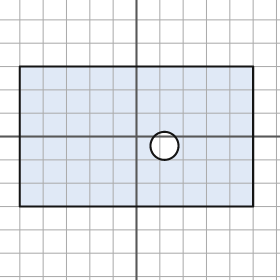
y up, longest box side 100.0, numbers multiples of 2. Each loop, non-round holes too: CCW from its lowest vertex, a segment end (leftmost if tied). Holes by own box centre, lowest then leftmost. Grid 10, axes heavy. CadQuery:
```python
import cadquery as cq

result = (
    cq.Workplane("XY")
    .moveTo(-50.0, -30.0)
    .lineTo(50.0, -30.0)
    .lineTo(50.0, 30.0)
    .lineTo(-50.0, 30.0)
    .close()
    .moveTo(12.0, -4.0)
    .circle(6.0)
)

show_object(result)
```